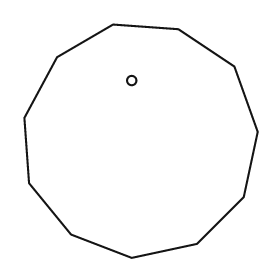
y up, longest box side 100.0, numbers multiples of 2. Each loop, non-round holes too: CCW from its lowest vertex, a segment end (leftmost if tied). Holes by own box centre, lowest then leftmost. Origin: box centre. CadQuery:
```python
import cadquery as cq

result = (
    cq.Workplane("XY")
    .moveTo(-4.0, -50.0)
    .lineTo(24.0, -44.0)
    .lineTo(44.0, -24.0)
    .lineTo(50.0, 4.0)
    .lineTo(40.0, 32.0)
    .lineTo(16.0, 48.0)
    .lineTo(-12.0, 50.0)
    .lineTo(-36.0, 36.0)
    .lineTo(-50.0, 10.0)
    .lineTo(-48.0, -18.0)
    .lineTo(-30.0, -40.0)
    .close()
    .moveTo(-4.0, 26.0)
    .circle(2.0)
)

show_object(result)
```